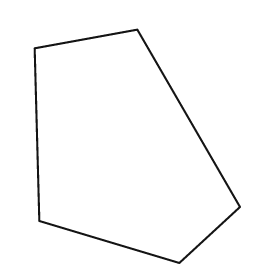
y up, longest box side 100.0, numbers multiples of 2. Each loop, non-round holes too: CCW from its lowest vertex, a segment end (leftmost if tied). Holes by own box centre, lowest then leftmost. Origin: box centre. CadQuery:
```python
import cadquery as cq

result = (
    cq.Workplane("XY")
    .moveTo(18.0, -50.0)
    .lineTo(44.0, -26.0)
    .lineTo(0.0, 50.0)
    .lineTo(-44.0, 42.0)
    .lineTo(-42.0, -32.0)
    .close()
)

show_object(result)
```